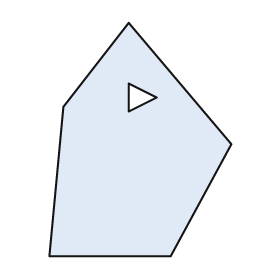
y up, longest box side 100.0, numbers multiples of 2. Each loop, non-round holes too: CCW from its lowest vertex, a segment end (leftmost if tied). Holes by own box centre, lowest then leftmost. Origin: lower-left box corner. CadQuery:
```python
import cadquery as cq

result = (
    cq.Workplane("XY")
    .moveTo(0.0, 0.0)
    .lineTo(52.0, 0.0)
    .lineTo(78.0, 48.0)
    .lineTo(34.0, 100.0)
    .lineTo(6.0, 64.0)
    .close()
    .moveTo(34.0, 62.0)
    .lineTo(46.0, 68.0)
    .lineTo(34.0, 74.0)
    .close()
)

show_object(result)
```